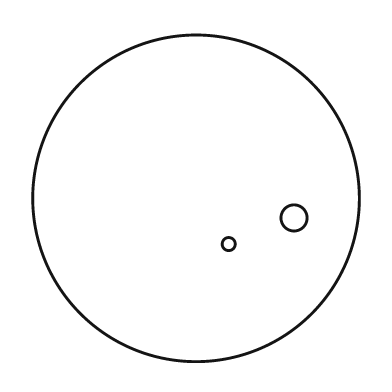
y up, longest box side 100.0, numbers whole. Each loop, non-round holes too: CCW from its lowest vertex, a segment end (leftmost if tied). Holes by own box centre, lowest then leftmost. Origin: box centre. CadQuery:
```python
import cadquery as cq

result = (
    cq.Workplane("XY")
    .moveTo(0.0, 0.0)
    .circle(50.0)
    .moveTo(10.0, -14.0)
    .circle(2.0)
    .moveTo(30.0, -6.0)
    .circle(4.0)
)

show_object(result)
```